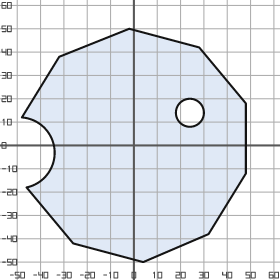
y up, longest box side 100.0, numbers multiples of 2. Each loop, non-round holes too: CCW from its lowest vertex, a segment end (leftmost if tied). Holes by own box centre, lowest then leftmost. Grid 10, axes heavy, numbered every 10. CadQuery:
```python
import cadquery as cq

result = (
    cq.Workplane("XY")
    .moveTo(4.0, -50.0)
    .lineTo(32.0, -38.0)
    .lineTo(48.0, -12.0)
    .lineTo(48.0, 18.0)
    .lineTo(28.0, 42.0)
    .lineTo(-2.0, 50.0)
    .lineTo(-32.0, 38.0)
    .lineTo(-48.0, 12.0)
    .threePointArc((-34.0, -2.0), (-46.0, -18.0))
    .lineTo(-26.0, -42.0)
    .close()
    .moveTo(24.0, 14.0)
    .circle(6.0)
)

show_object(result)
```